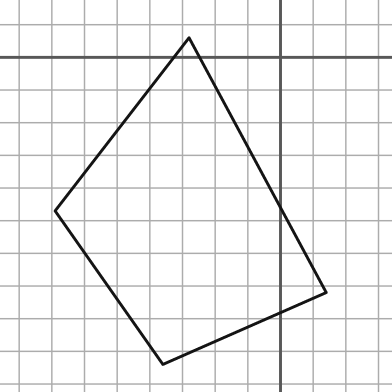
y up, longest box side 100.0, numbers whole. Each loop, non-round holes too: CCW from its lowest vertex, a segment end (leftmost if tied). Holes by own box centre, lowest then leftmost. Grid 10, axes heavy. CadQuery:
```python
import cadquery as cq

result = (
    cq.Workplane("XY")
    .moveTo(-36.0, -94.0)
    .lineTo(14.0, -72.0)
    .lineTo(-28.0, 6.0)
    .lineTo(-69.0, -47.0)
    .close()
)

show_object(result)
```